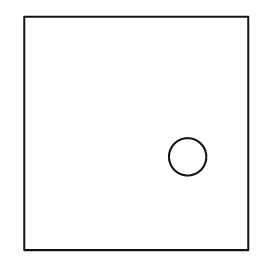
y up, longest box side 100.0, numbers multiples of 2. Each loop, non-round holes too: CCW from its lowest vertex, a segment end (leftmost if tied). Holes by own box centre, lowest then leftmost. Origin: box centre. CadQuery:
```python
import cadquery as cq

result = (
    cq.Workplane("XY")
    .moveTo(-48.0, -50.0)
    .lineTo(48.0, -50.0)
    .lineTo(48.0, 50.0)
    .lineTo(-48.0, 50.0)
    .close()
    .moveTo(22.0, -10.0)
    .circle(8.0)
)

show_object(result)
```